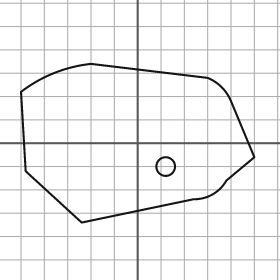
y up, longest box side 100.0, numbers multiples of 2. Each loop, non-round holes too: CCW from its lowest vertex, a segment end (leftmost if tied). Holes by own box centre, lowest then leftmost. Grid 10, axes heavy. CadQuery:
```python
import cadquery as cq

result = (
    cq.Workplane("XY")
    .moveTo(-24.0, -34.0)
    .lineTo(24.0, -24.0)
    .threePointArc((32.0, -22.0), (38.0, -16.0))
    .lineTo(50.0, -6.0)
    .lineTo(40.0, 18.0)
    .threePointArc((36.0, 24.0), (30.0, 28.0))
    .lineTo(-20.0, 34.0)
    .threePointArc((-36.0, 30.0), (-50.0, 22.0))
    .lineTo(-48.0, -12.0)
    .close()
    .moveTo(12.0, -10.0)
    .circle(4.0)
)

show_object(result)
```